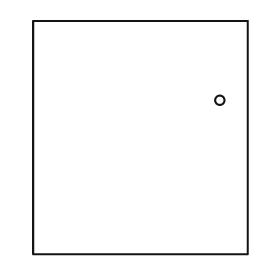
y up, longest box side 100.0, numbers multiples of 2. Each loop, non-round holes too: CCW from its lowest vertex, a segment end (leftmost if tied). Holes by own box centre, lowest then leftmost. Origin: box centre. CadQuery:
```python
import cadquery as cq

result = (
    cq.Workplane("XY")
    .moveTo(-46.0, -50.0)
    .lineTo(46.0, -50.0)
    .lineTo(46.0, 50.0)
    .lineTo(-46.0, 50.0)
    .close()
    .moveTo(34.0, 16.0)
    .circle(2.0)
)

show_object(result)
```